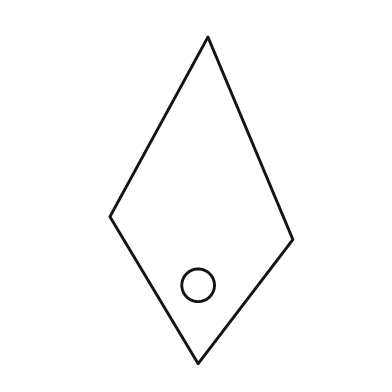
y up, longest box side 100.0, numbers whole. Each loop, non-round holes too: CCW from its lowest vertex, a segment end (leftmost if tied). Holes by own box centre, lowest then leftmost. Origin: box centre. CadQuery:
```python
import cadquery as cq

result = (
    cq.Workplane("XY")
    .moveTo(-1.0, -50.0)
    .lineTo(28.0, -12.0)
    .lineTo(2.0, 50.0)
    .lineTo(-28.0, -5.0)
    .close()
    .moveTo(-1.0, -26.0)
    .circle(5.0)
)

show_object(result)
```